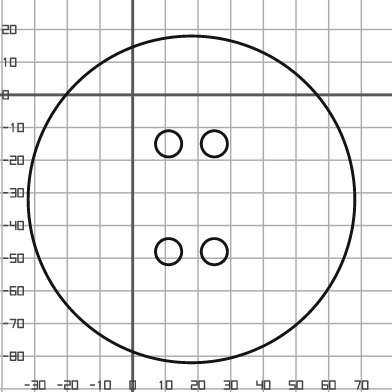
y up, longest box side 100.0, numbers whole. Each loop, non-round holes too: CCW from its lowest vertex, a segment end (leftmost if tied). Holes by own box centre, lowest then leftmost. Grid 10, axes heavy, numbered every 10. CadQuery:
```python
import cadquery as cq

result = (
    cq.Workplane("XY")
    .moveTo(18.0, -32.0)
    .circle(50.0)
    .moveTo(11.0, -48.0)
    .circle(4.0)
    .moveTo(25.0, -48.0)
    .circle(4.0)
    .moveTo(11.0, -15.0)
    .circle(4.0)
    .moveTo(25.0, -15.0)
    .circle(4.0)
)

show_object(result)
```